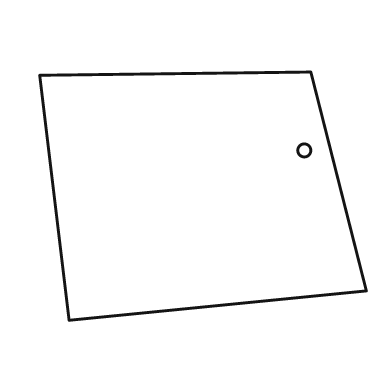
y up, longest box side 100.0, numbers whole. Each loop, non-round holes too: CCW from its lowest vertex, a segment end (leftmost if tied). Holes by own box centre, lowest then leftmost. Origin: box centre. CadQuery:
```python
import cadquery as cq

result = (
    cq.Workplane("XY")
    .moveTo(-41.0, -38.0)
    .lineTo(50.0, -29.0)
    .lineTo(33.0, 38.0)
    .lineTo(-50.0, 37.0)
    .close()
    .moveTo(31.0, 14.0)
    .circle(2.0)
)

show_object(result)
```